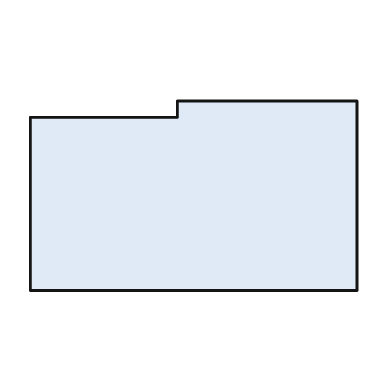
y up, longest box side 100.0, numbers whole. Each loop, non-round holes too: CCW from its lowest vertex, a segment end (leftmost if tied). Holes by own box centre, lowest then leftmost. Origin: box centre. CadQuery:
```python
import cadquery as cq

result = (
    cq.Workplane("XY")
    .moveTo(-50.0, -29.0)
    .lineTo(50.0, -29.0)
    .lineTo(50.0, 29.0)
    .lineTo(-5.0, 29.0)
    .lineTo(-5.0, 24.0)
    .lineTo(-50.0, 24.0)
    .close()
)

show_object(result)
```